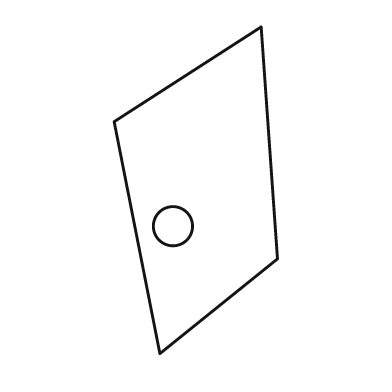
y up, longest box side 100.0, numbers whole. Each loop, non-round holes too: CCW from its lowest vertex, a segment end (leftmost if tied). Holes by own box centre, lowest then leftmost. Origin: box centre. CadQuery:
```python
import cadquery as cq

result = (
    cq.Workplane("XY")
    .moveTo(-11.0, -50.0)
    .lineTo(25.0, -21.0)
    .lineTo(20.0, 50.0)
    .lineTo(-25.0, 21.0)
    .close()
    .moveTo(-7.0, -11.0)
    .circle(6.0)
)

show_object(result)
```